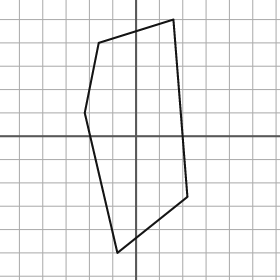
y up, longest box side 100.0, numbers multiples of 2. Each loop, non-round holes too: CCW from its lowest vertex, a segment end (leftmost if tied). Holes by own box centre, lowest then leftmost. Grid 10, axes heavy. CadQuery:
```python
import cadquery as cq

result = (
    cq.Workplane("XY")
    .moveTo(-8.0, -50.0)
    .lineTo(22.0, -26.0)
    .lineTo(16.0, 50.0)
    .lineTo(-16.0, 40.0)
    .lineTo(-22.0, 10.0)
    .close()
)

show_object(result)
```